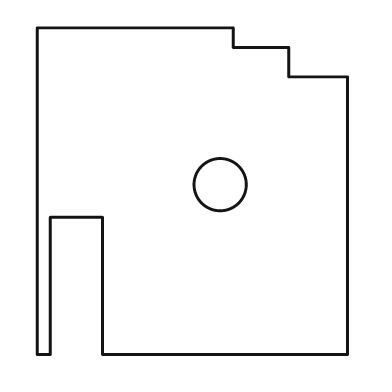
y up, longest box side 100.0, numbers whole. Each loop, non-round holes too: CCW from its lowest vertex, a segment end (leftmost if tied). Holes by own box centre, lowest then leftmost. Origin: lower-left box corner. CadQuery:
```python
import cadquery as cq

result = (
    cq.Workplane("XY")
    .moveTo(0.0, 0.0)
    .lineTo(4.0, 0.0)
    .lineTo(4.0, 42.0)
    .lineTo(20.0, 42.0)
    .lineTo(20.0, 0.0)
    .lineTo(95.0, 0.0)
    .lineTo(95.0, 85.0)
    .lineTo(77.0, 85.0)
    .lineTo(77.0, 94.0)
    .lineTo(60.0, 94.0)
    .lineTo(60.0, 100.0)
    .lineTo(0.0, 100.0)
    .close()
    .moveTo(56.0, 52.0)
    .circle(8.0)
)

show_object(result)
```